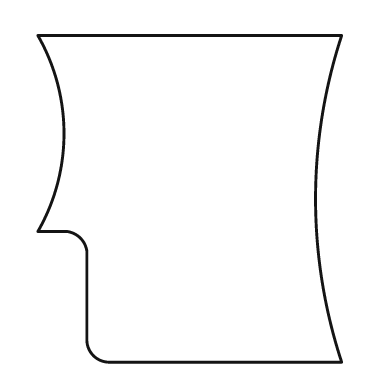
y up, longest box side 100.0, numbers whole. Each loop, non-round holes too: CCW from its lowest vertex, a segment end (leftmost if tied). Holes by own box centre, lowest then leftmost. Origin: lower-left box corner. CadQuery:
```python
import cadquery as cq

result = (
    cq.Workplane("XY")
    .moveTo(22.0, 0.0)
    .lineTo(93.0, 0.0)
    .threePointArc((85.0, 50.0), (93.0, 100.0))
    .lineTo(0.0, 100.0)
    .threePointArc((8.0, 70.0), (0.0, 40.0))
    .lineTo(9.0, 40.0)
    .threePointArc((13.0, 38.0), (15.0, 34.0))
    .lineTo(15.0, 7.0)
    .threePointArc((17.0, 2.0), (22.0, 0.0))
    .close()
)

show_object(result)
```